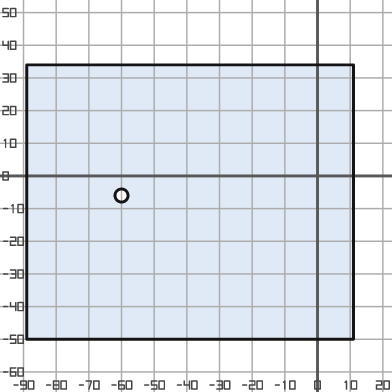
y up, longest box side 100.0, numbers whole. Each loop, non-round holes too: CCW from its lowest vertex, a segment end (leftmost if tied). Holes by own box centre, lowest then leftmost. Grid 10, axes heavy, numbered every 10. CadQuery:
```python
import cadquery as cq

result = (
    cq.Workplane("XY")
    .moveTo(-89.0, -50.0)
    .lineTo(11.0, -50.0)
    .lineTo(11.0, 34.0)
    .lineTo(-89.0, 34.0)
    .close()
    .moveTo(-60.0, -6.0)
    .circle(2.0)
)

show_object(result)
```